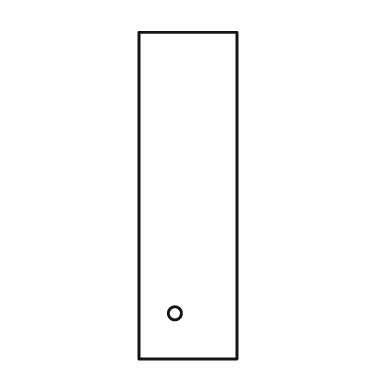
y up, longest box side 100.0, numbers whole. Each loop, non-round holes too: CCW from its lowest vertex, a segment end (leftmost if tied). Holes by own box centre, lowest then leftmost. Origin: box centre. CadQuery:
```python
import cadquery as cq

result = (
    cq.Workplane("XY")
    .moveTo(-15.0, -50.0)
    .lineTo(15.0, -50.0)
    .lineTo(15.0, 50.0)
    .lineTo(-15.0, 50.0)
    .close()
    .moveTo(-4.0, -36.0)
    .circle(2.0)
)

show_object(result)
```